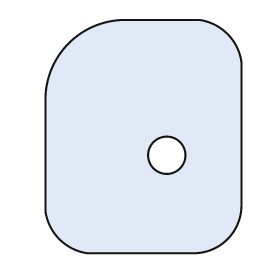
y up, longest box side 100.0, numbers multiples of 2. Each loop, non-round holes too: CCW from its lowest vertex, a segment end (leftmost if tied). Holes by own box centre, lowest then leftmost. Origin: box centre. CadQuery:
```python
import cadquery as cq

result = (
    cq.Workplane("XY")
    .moveTo(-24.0, -50.0)
    .lineTo(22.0, -50.0)
    .threePointArc((36.0, -44.0), (42.0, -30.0))
    .lineTo(42.0, 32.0)
    .threePointArc((36.0, 44.0), (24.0, 50.0))
    .lineTo(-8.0, 50.0)
    .threePointArc((-32.0, 40.0), (-42.0, 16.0))
    .lineTo(-42.0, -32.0)
    .threePointArc((-36.0, -44.0), (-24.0, -50.0))
    .close()
    .moveTo(10.0, -8.0)
    .circle(8.0)
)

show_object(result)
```